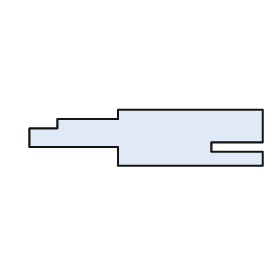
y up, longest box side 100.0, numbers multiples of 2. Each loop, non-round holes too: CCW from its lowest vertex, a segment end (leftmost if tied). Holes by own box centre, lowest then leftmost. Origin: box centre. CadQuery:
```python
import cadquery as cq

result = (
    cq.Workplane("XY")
    .moveTo(-12.0, -12.0)
    .lineTo(50.0, -12.0)
    .lineTo(50.0, -6.0)
    .lineTo(28.0, -6.0)
    .lineTo(28.0, -2.0)
    .lineTo(50.0, -2.0)
    .lineTo(50.0, 12.0)
    .lineTo(-12.0, 12.0)
    .lineTo(-12.0, 8.0)
    .lineTo(-38.0, 8.0)
    .lineTo(-38.0, 4.0)
    .lineTo(-50.0, 4.0)
    .lineTo(-50.0, -4.0)
    .lineTo(-12.0, -4.0)
    .close()
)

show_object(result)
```